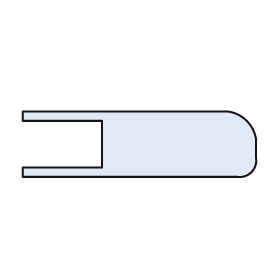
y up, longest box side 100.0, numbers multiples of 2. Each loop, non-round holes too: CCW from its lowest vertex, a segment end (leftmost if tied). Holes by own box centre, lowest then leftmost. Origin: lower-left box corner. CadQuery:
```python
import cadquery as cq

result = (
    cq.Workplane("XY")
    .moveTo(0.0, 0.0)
    .lineTo(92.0, 0.0)
    .threePointArc((98.0, 2.0), (100.0, 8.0))
    .lineTo(100.0, 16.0)
    .threePointArc((96.0, 24.0), (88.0, 28.0))
    .lineTo(0.0, 28.0)
    .lineTo(0.0, 24.0)
    .lineTo(34.0, 24.0)
    .lineTo(34.0, 4.0)
    .lineTo(0.0, 4.0)
    .close()
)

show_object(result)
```